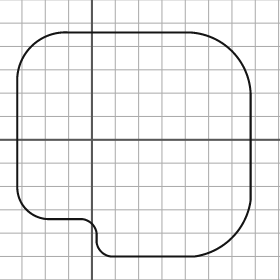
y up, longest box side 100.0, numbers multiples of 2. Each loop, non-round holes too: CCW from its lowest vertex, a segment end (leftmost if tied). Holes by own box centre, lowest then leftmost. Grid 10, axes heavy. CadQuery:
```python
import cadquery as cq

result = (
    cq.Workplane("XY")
    .moveTo(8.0, -50.0)
    .lineTo(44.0, -50.0)
    .threePointArc((60.0, -42.0), (68.0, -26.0))
    .lineTo(68.0, 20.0)
    .threePointArc((60.0, 38.0), (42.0, 46.0))
    .lineTo(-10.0, 46.0)
    .threePointArc((-26.0, 40.0), (-32.0, 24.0))
    .lineTo(-32.0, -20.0)
    .threePointArc((-28.0, -30.0), (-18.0, -34.0))
    .lineTo(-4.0, -34.0)
    .threePointArc((0.0, -36.0), (2.0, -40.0))
    .lineTo(2.0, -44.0)
    .threePointArc((4.0, -48.0), (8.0, -50.0))
    .close()
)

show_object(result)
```